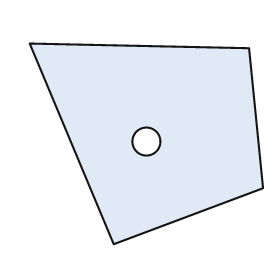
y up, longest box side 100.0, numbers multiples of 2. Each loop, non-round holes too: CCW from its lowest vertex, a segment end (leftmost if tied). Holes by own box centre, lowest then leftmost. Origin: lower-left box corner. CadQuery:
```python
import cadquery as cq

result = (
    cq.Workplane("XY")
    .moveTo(36.0, 0.0)
    .lineTo(100.0, 24.0)
    .lineTo(94.0, 84.0)
    .lineTo(0.0, 86.0)
    .close()
    .moveTo(50.0, 44.0)
    .circle(6.0)
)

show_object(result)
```